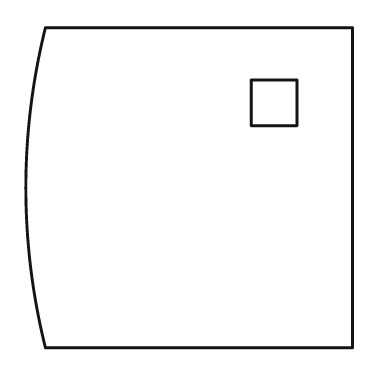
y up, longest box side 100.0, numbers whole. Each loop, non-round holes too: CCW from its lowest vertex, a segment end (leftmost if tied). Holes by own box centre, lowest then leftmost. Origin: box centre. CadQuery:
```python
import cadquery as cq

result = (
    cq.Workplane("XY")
    .moveTo(-44.0, -49.0)
    .lineTo(50.0, -49.0)
    .lineTo(50.0, 49.0)
    .lineTo(-44.0, 49.0)
    .threePointArc((-50.0, 0.0), (-44.0, -49.0))
    .close()
    .moveTo(19.0, 19.0)
    .lineTo(33.0, 19.0)
    .lineTo(33.0, 33.0)
    .lineTo(19.0, 33.0)
    .close()
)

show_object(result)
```